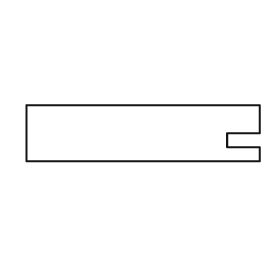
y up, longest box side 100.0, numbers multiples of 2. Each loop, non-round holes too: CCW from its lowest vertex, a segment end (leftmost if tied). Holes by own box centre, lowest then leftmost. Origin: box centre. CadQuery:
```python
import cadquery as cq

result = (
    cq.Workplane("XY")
    .moveTo(-50.0, -12.0)
    .lineTo(50.0, -12.0)
    .lineTo(50.0, -6.0)
    .lineTo(36.0, -6.0)
    .lineTo(36.0, 0.0)
    .lineTo(50.0, 0.0)
    .lineTo(50.0, 12.0)
    .lineTo(-50.0, 12.0)
    .close()
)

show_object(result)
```